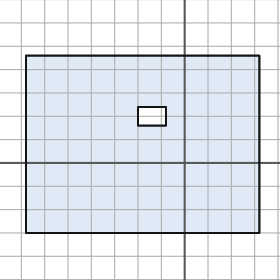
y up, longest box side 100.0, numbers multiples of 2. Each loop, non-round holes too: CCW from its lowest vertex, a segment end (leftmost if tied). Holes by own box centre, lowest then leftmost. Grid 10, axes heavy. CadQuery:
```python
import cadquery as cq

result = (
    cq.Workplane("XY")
    .moveTo(-68.0, -30.0)
    .lineTo(32.0, -30.0)
    .lineTo(32.0, 46.0)
    .lineTo(-68.0, 46.0)
    .close()
    .moveTo(-20.0, 16.0)
    .lineTo(-8.0, 16.0)
    .lineTo(-8.0, 24.0)
    .lineTo(-20.0, 24.0)
    .close()
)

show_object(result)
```